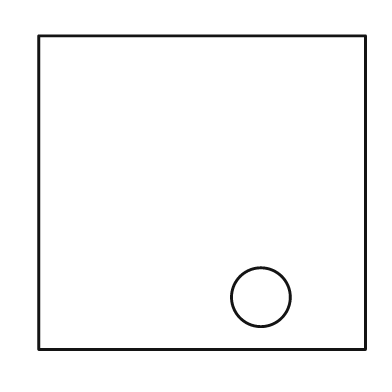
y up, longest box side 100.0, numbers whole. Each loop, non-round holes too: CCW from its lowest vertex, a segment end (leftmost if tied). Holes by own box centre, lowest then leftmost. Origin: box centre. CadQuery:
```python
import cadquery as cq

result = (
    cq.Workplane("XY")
    .moveTo(-50.0, -48.0)
    .lineTo(50.0, -48.0)
    .lineTo(50.0, 48.0)
    .lineTo(-50.0, 48.0)
    .close()
    .moveTo(18.0, -32.0)
    .circle(9.0)
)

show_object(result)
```